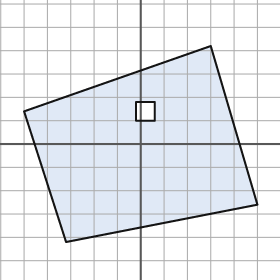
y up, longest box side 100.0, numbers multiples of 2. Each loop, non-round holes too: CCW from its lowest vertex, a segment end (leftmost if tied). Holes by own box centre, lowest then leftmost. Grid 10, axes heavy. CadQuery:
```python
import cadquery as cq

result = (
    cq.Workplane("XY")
    .moveTo(-32.0, -42.0)
    .lineTo(50.0, -26.0)
    .lineTo(30.0, 42.0)
    .lineTo(-50.0, 14.0)
    .close()
    .moveTo(-2.0, 10.0)
    .lineTo(6.0, 10.0)
    .lineTo(6.0, 18.0)
    .lineTo(-2.0, 18.0)
    .close()
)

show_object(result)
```